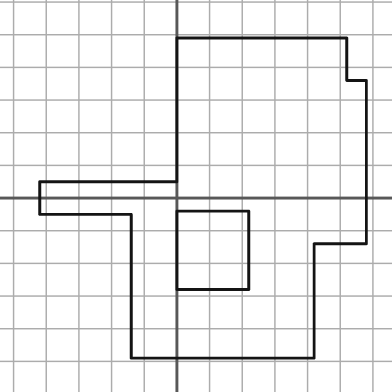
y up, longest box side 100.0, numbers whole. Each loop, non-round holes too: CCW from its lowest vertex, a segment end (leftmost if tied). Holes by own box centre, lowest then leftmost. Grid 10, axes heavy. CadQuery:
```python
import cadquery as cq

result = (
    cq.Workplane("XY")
    .moveTo(-14.0, -49.0)
    .lineTo(42.0, -49.0)
    .lineTo(42.0, -14.0)
    .lineTo(58.0, -14.0)
    .lineTo(58.0, 36.0)
    .lineTo(52.0, 36.0)
    .lineTo(52.0, 49.0)
    .lineTo(0.0, 49.0)
    .lineTo(0.0, 5.0)
    .lineTo(-42.0, 5.0)
    .lineTo(-42.0, -5.0)
    .lineTo(-14.0, -5.0)
    .close()
    .moveTo(0.0, -28.0)
    .lineTo(22.0, -28.0)
    .lineTo(22.0, -4.0)
    .lineTo(0.0, -4.0)
    .close()
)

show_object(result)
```